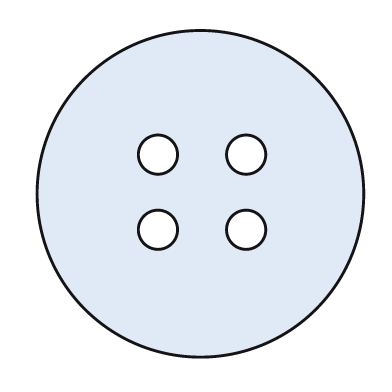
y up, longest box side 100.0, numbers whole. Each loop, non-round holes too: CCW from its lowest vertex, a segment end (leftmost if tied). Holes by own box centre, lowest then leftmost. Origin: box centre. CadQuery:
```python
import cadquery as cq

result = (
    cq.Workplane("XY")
    .moveTo(0.0, 0.0)
    .circle(50.0)
    .moveTo(-13.0, -11.0)
    .circle(6.0)
    .moveTo(14.0, -11.0)
    .circle(6.0)
    .moveTo(-13.0, 12.0)
    .circle(6.0)
    .moveTo(14.0, 12.0)
    .circle(6.0)
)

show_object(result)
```